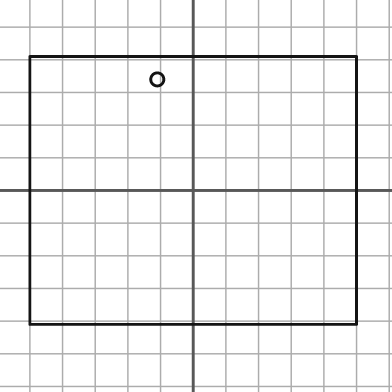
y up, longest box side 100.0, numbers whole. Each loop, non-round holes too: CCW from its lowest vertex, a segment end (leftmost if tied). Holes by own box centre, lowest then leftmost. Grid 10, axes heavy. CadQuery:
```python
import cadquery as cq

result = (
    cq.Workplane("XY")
    .moveTo(-50.0, -41.0)
    .lineTo(50.0, -41.0)
    .lineTo(50.0, 41.0)
    .lineTo(-50.0, 41.0)
    .close()
    .moveTo(-11.0, 34.0)
    .circle(2.0)
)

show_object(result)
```